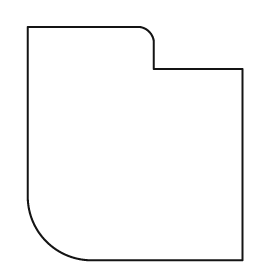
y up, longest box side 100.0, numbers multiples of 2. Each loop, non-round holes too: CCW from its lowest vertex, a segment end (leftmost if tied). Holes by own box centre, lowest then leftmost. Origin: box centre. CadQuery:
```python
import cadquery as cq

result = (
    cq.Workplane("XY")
    .moveTo(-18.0, -50.0)
    .lineTo(46.0, -50.0)
    .lineTo(46.0, 32.0)
    .lineTo(8.0, 32.0)
    .lineTo(8.0, 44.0)
    .threePointArc((6.0, 48.0), (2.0, 50.0))
    .lineTo(-46.0, 50.0)
    .lineTo(-46.0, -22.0)
    .threePointArc((-38.0, -42.0), (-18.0, -50.0))
    .close()
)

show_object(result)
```